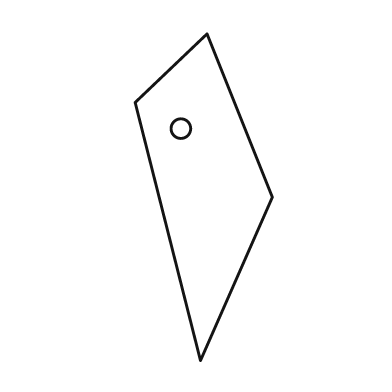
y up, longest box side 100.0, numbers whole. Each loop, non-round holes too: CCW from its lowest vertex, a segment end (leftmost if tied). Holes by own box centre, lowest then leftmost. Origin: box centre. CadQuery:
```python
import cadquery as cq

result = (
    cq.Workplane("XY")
    .moveTo(-1.0, -50.0)
    .lineTo(21.0, 0.0)
    .lineTo(1.0, 50.0)
    .lineTo(-21.0, 29.0)
    .close()
    .moveTo(-7.0, 21.0)
    .circle(3.0)
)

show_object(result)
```